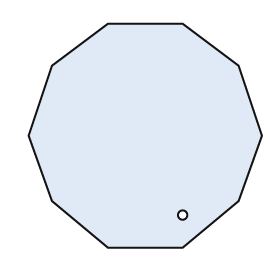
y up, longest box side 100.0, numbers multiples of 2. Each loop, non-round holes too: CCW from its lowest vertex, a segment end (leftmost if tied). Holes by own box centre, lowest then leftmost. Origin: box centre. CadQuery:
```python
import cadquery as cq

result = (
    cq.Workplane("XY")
    .moveTo(-16.0, -48.0)
    .lineTo(16.0, -48.0)
    .lineTo(40.0, -28.0)
    .lineTo(50.0, 0.0)
    .lineTo(40.0, 30.0)
    .lineTo(16.0, 48.0)
    .lineTo(-16.0, 48.0)
    .lineTo(-40.0, 30.0)
    .lineTo(-50.0, 0.0)
    .lineTo(-40.0, -28.0)
    .close()
    .moveTo(16.0, -34.0)
    .circle(2.0)
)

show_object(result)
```